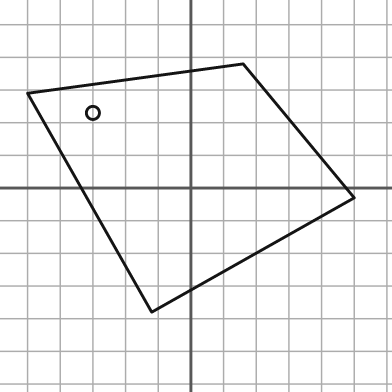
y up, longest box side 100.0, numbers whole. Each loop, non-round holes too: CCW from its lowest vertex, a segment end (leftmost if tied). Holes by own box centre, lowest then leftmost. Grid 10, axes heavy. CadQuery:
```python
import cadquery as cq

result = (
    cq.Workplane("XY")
    .moveTo(-12.0, -38.0)
    .lineTo(50.0, -3.0)
    .lineTo(16.0, 38.0)
    .lineTo(-50.0, 29.0)
    .close()
    .moveTo(-30.0, 23.0)
    .circle(2.0)
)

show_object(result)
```